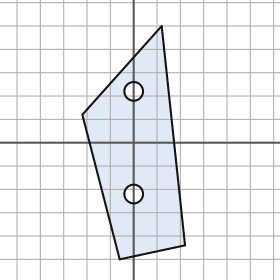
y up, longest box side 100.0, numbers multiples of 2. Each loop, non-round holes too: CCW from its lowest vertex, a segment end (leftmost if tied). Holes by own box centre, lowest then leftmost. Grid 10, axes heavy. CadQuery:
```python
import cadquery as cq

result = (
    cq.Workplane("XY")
    .moveTo(-6.0, -50.0)
    .lineTo(22.0, -44.0)
    .lineTo(12.0, 50.0)
    .lineTo(-22.0, 12.0)
    .close()
    .moveTo(0.0, -22.0)
    .circle(4.0)
    .moveTo(0.0, 22.0)
    .circle(4.0)
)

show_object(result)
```